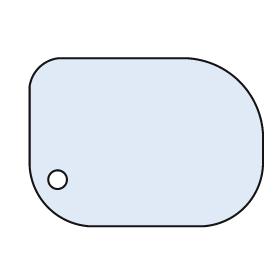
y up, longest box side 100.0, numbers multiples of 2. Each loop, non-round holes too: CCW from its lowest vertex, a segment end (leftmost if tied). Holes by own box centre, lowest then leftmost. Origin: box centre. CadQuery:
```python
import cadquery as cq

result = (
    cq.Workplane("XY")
    .moveTo(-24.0, -36.0)
    .lineTo(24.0, -36.0)
    .threePointArc((42.0, -28.0), (50.0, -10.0))
    .lineTo(50.0, 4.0)
    .threePointArc((40.0, 26.0), (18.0, 36.0))
    .lineTo(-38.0, 36.0)
    .threePointArc((-46.0, 32.0), (-50.0, 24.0))
    .lineTo(-50.0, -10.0)
    .threePointArc((-42.0, -28.0), (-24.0, -36.0))
    .close()
    .moveTo(-38.0, -16.0)
    .circle(4.0)
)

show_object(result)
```